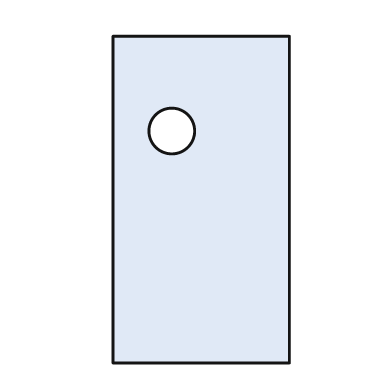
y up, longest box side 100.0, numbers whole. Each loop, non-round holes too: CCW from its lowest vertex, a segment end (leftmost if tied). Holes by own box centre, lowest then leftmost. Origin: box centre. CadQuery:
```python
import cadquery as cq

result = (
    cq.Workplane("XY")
    .moveTo(-27.0, -50.0)
    .lineTo(27.0, -50.0)
    .lineTo(27.0, 50.0)
    .lineTo(-27.0, 50.0)
    .close()
    .moveTo(-9.0, 21.0)
    .circle(7.0)
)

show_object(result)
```